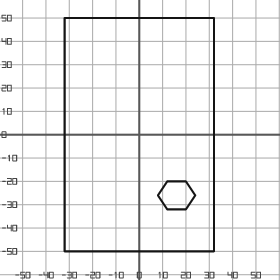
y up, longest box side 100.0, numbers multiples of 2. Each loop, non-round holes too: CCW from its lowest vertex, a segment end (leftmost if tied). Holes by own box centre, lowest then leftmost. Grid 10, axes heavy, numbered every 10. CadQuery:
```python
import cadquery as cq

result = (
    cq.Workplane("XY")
    .moveTo(-32.0, -50.0)
    .lineTo(32.0, -50.0)
    .lineTo(32.0, 50.0)
    .lineTo(-32.0, 50.0)
    .close()
    .moveTo(12.0, -32.0)
    .lineTo(20.0, -32.0)
    .lineTo(24.0, -26.0)
    .lineTo(20.0, -20.0)
    .lineTo(12.0, -20.0)
    .lineTo(8.0, -26.0)
    .close()
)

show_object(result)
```